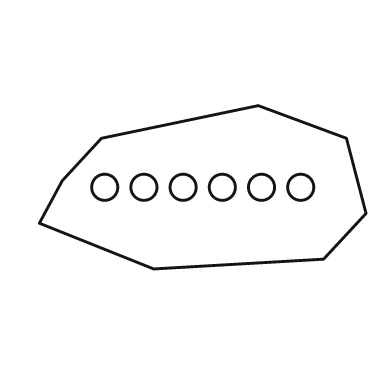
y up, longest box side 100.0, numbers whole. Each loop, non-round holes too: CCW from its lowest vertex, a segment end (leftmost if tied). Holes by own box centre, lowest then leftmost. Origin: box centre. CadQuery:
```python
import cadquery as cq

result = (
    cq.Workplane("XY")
    .moveTo(-15.0, -25.0)
    .lineTo(37.0, -22.0)
    .lineTo(50.0, -8.0)
    .lineTo(44.0, 15.0)
    .lineTo(17.0, 25.0)
    .lineTo(-31.0, 15.0)
    .lineTo(-43.0, 2.0)
    .lineTo(-50.0, -11.0)
    .close()
    .moveTo(-30.0, 0.0)
    .circle(4.0)
    .moveTo(-18.0, 0.0)
    .circle(4.0)
    .moveTo(-6.0, 0.0)
    .circle(4.0)
    .moveTo(6.0, 0.0)
    .circle(4.0)
    .moveTo(18.0, 0.0)
    .circle(4.0)
    .moveTo(30.0, 0.0)
    .circle(4.0)
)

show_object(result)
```